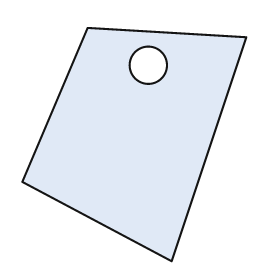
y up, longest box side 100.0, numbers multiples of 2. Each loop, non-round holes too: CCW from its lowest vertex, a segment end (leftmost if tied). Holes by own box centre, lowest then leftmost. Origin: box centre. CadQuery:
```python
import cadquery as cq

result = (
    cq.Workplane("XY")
    .moveTo(16.0, -50.0)
    .lineTo(48.0, 46.0)
    .lineTo(-20.0, 50.0)
    .lineTo(-48.0, -16.0)
    .close()
    .moveTo(6.0, 34.0)
    .circle(8.0)
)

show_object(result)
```